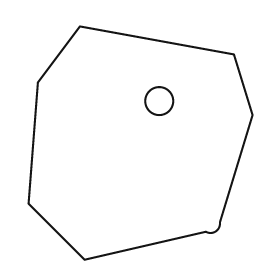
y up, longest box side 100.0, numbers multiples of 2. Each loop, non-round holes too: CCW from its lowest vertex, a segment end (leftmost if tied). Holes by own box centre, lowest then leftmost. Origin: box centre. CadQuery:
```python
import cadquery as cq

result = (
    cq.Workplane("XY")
    .moveTo(-24.0, -50.0)
    .lineTo(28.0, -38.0)
    .threePointArc((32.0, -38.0), (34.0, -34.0))
    .lineTo(48.0, 12.0)
    .lineTo(40.0, 38.0)
    .lineTo(-26.0, 50.0)
    .lineTo(-44.0, 26.0)
    .lineTo(-48.0, -26.0)
    .close()
    .moveTo(8.0, 18.0)
    .circle(6.0)
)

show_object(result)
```